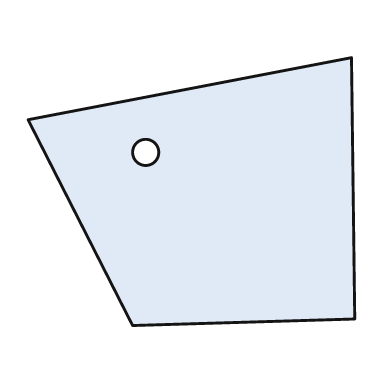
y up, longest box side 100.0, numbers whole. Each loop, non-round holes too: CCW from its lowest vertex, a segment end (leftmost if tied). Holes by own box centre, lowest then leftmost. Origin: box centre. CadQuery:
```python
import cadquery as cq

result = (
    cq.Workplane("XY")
    .moveTo(-18.0, -41.0)
    .lineTo(50.0, -39.0)
    .lineTo(49.0, 41.0)
    .lineTo(-50.0, 22.0)
    .close()
    .moveTo(-14.0, 12.0)
    .circle(4.0)
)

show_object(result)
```